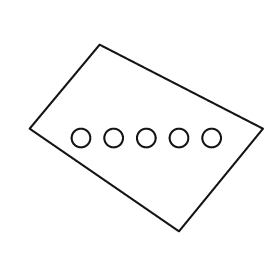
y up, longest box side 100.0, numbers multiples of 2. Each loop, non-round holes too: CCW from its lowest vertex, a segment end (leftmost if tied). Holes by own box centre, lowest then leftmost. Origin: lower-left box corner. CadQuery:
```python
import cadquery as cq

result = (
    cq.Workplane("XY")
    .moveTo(64.0, 0.0)
    .lineTo(100.0, 44.0)
    .lineTo(30.0, 80.0)
    .lineTo(0.0, 44.0)
    .close()
    .moveTo(22.0, 40.0)
    .circle(4.0)
    .moveTo(36.0, 40.0)
    .circle(4.0)
    .moveTo(50.0, 40.0)
    .circle(4.0)
    .moveTo(64.0, 40.0)
    .circle(4.0)
    .moveTo(78.0, 40.0)
    .circle(4.0)
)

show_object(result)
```